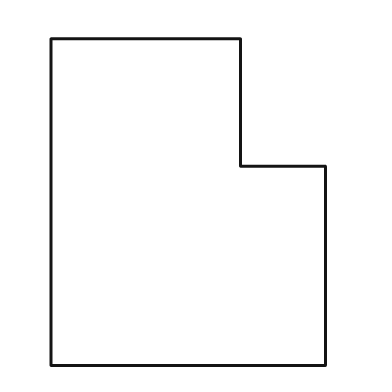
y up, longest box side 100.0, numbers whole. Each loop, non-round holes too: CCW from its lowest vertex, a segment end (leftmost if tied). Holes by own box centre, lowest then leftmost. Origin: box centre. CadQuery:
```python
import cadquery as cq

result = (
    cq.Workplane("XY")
    .moveTo(-42.0, -50.0)
    .lineTo(42.0, -50.0)
    .lineTo(42.0, 11.0)
    .lineTo(16.0, 11.0)
    .lineTo(16.0, 50.0)
    .lineTo(-42.0, 50.0)
    .close()
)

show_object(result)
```